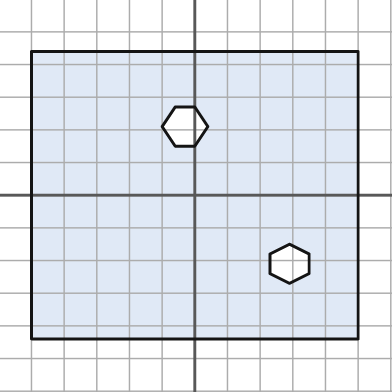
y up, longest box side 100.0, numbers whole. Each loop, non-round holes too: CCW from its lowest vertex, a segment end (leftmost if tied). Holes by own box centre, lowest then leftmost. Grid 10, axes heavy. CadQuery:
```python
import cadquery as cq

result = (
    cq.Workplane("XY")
    .moveTo(-50.0, -44.0)
    .lineTo(50.0, -44.0)
    .lineTo(50.0, 44.0)
    .lineTo(-50.0, 44.0)
    .close()
    .moveTo(29.0, -27.0)
    .lineTo(35.0, -24.0)
    .lineTo(35.0, -18.0)
    .lineTo(29.0, -15.0)
    .lineTo(23.0, -18.0)
    .lineTo(23.0, -24.0)
    .close()
    .moveTo(-6.0, 15.0)
    .lineTo(0.0, 15.0)
    .lineTo(4.0, 21.0)
    .lineTo(0.0, 27.0)
    .lineTo(-6.0, 27.0)
    .lineTo(-10.0, 21.0)
    .close()
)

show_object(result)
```